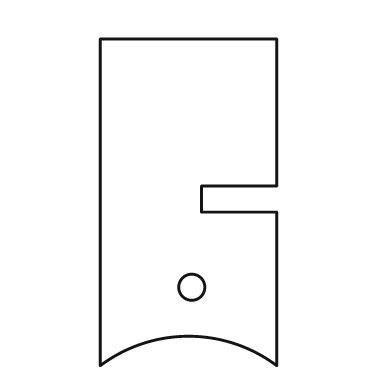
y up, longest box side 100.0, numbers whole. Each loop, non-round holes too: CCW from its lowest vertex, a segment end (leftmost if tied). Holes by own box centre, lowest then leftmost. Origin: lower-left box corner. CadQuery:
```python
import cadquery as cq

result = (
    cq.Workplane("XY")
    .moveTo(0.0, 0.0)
    .threePointArc((27.0, 9.0), (54.0, 0.0))
    .lineTo(54.0, 47.0)
    .lineTo(31.0, 47.0)
    .lineTo(31.0, 55.0)
    .lineTo(54.0, 55.0)
    .lineTo(54.0, 100.0)
    .lineTo(0.0, 100.0)
    .close()
    .moveTo(28.0, 24.0)
    .circle(4.0)
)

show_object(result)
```